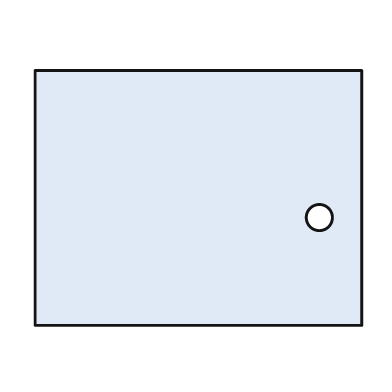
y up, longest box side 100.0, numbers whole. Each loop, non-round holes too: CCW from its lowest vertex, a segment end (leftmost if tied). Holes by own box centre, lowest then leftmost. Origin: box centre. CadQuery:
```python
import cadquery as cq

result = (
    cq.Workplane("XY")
    .moveTo(-50.0, -39.0)
    .lineTo(50.0, -39.0)
    .lineTo(50.0, 39.0)
    .lineTo(-50.0, 39.0)
    .close()
    .moveTo(37.0, -6.0)
    .circle(4.0)
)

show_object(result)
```